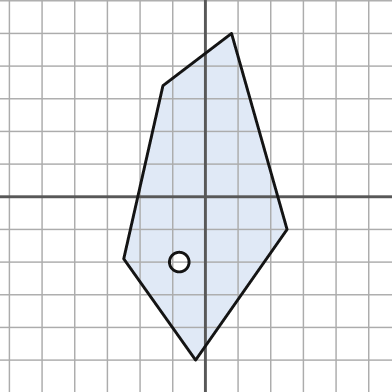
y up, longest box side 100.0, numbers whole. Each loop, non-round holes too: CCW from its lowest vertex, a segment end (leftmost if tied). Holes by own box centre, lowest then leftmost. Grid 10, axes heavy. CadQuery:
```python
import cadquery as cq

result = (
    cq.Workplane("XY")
    .moveTo(-3.0, -50.0)
    .lineTo(25.0, -10.0)
    .lineTo(8.0, 50.0)
    .lineTo(-13.0, 34.0)
    .lineTo(-25.0, -19.0)
    .close()
    .moveTo(-8.0, -20.0)
    .circle(3.0)
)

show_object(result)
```